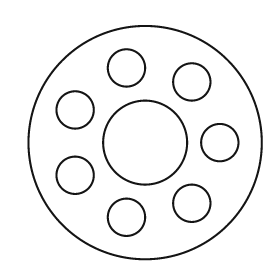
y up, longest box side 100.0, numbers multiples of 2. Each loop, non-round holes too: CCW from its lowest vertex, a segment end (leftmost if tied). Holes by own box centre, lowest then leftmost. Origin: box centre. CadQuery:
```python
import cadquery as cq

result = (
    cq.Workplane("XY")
    .moveTo(0.0, 0.0)
    .circle(50.0)
    .moveTo(-8.0, -32.0)
    .circle(8.0)
    .moveTo(20.0, -26.0)
    .circle(8.0)
    .moveTo(-30.0, -14.0)
    .circle(8.0)
    .moveTo(0.0, 0.0)
    .circle(18.0)
    .moveTo(32.0, 0.0)
    .circle(8.0)
    .moveTo(-30.0, 14.0)
    .circle(8.0)
    .moveTo(20.0, 26.0)
    .circle(8.0)
    .moveTo(-8.0, 32.0)
    .circle(8.0)
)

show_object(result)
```